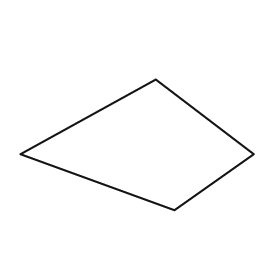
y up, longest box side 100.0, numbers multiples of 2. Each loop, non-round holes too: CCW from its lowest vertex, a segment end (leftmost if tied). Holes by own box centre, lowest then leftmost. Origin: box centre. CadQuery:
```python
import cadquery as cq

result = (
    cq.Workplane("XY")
    .moveTo(16.0, -28.0)
    .lineTo(50.0, -4.0)
    .lineTo(8.0, 28.0)
    .lineTo(-50.0, -4.0)
    .close()
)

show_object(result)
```